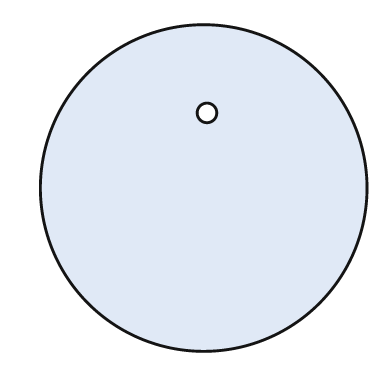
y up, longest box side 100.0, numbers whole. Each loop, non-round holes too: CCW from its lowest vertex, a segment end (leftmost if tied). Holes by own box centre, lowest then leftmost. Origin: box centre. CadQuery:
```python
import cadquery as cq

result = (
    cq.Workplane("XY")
    .moveTo(0.0, 0.0)
    .circle(50.0)
    .moveTo(1.0, 23.0)
    .circle(3.0)
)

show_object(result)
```